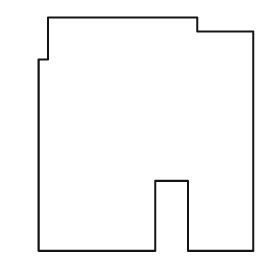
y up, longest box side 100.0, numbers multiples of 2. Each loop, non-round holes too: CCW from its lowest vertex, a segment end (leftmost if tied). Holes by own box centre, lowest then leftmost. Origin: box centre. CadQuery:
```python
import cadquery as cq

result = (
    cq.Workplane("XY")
    .moveTo(-46.0, -50.0)
    .lineTo(4.0, -50.0)
    .lineTo(4.0, -20.0)
    .lineTo(18.0, -20.0)
    .lineTo(18.0, -50.0)
    .lineTo(46.0, -50.0)
    .lineTo(46.0, 44.0)
    .lineTo(22.0, 44.0)
    .lineTo(22.0, 50.0)
    .lineTo(-42.0, 50.0)
    .lineTo(-42.0, 32.0)
    .lineTo(-46.0, 32.0)
    .close()
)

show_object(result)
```